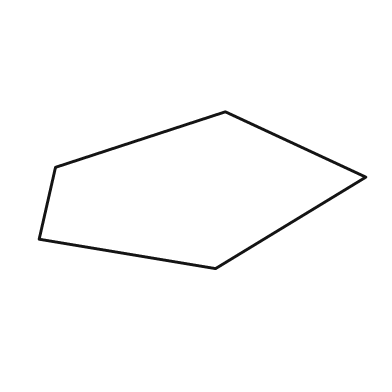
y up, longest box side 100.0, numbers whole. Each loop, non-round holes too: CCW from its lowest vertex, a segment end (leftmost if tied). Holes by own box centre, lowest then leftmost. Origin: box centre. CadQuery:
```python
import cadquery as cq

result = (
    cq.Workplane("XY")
    .moveTo(4.0, -24.0)
    .lineTo(50.0, 4.0)
    .lineTo(7.0, 24.0)
    .lineTo(-45.0, 7.0)
    .lineTo(-50.0, -15.0)
    .close()
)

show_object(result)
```